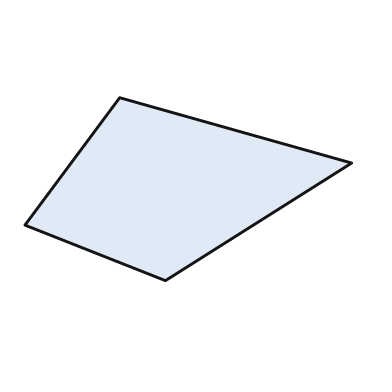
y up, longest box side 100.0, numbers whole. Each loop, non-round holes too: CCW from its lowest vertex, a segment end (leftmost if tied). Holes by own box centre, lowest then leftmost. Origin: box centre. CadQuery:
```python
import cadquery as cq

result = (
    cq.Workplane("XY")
    .moveTo(-7.0, -28.0)
    .lineTo(50.0, 8.0)
    .lineTo(-21.0, 28.0)
    .lineTo(-50.0, -11.0)
    .close()
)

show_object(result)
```